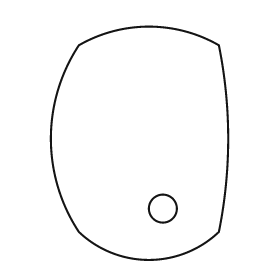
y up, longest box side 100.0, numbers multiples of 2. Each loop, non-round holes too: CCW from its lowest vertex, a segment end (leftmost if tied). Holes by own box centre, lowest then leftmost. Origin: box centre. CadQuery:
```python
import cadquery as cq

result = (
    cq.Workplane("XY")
    .moveTo(-26.0, -38.0)
    .threePointArc((4.0, -50.0), (34.0, -38.0))
    .threePointArc((38.0, 2.0), (34.0, 42.0))
    .threePointArc((4.0, 50.0), (-26.0, 42.0))
    .threePointArc((-38.0, 2.0), (-26.0, -38.0))
    .close()
    .moveTo(10.0, -28.0)
    .circle(6.0)
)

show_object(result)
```